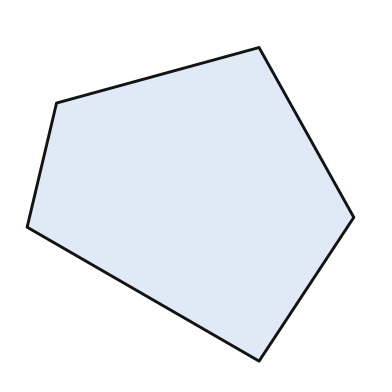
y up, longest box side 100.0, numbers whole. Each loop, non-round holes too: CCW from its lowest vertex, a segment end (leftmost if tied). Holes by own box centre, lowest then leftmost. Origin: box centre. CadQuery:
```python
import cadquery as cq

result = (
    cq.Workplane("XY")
    .moveTo(21.0, -48.0)
    .lineTo(50.0, -4.0)
    .lineTo(21.0, 48.0)
    .lineTo(-41.0, 31.0)
    .lineTo(-50.0, -7.0)
    .close()
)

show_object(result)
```